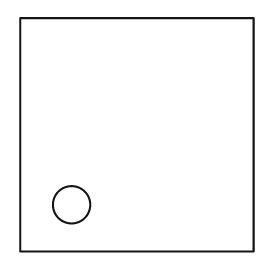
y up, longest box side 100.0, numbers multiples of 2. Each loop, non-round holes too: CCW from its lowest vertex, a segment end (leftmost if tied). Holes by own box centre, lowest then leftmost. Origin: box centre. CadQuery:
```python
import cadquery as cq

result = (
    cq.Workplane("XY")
    .moveTo(-50.0, -50.0)
    .lineTo(50.0, -50.0)
    .lineTo(50.0, 50.0)
    .lineTo(-50.0, 50.0)
    .close()
    .moveTo(-28.0, -30.0)
    .circle(8.0)
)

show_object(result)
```